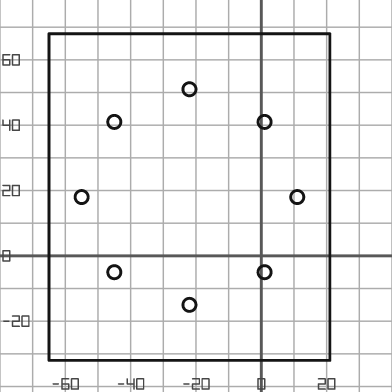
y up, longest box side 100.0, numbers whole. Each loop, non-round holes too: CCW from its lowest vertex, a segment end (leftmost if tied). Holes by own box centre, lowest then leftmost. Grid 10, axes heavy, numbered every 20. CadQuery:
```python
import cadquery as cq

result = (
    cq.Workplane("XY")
    .moveTo(-65.0, -32.0)
    .lineTo(21.0, -32.0)
    .lineTo(21.0, 68.0)
    .lineTo(-65.0, 68.0)
    .close()
    .moveTo(-22.0, -15.0)
    .circle(2.0)
    .moveTo(-45.0, -5.0)
    .circle(2.0)
    .moveTo(1.0, -5.0)
    .circle(2.0)
    .moveTo(-55.0, 18.0)
    .circle(2.0)
    .moveTo(11.0, 18.0)
    .circle(2.0)
    .moveTo(-45.0, 41.0)
    .circle(2.0)
    .moveTo(1.0, 41.0)
    .circle(2.0)
    .moveTo(-22.0, 51.0)
    .circle(2.0)
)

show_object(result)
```